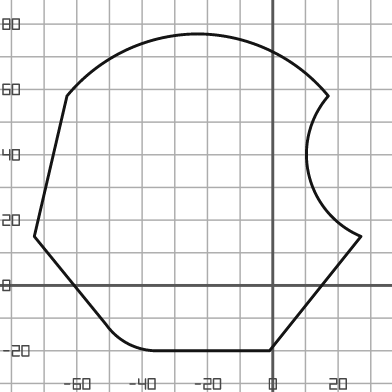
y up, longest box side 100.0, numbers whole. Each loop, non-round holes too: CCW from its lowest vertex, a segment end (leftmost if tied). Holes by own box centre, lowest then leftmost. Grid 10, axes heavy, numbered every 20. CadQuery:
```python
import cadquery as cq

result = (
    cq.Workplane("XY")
    .moveTo(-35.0, -20.0)
    .lineTo(-1.0, -20.0)
    .lineTo(27.0, 15.0)
    .threePointArc((11.0, 34.0), (17.0, 58.0))
    .threePointArc((-1.0, 72.0), (-23.0, 77.0))
    .threePointArc((-45.0, 72.0), (-63.0, 58.0))
    .lineTo(-73.0, 15.0)
    .lineTo(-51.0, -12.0)
    .threePointArc((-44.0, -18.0), (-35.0, -20.0))
    .close()
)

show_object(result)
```